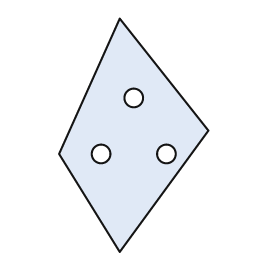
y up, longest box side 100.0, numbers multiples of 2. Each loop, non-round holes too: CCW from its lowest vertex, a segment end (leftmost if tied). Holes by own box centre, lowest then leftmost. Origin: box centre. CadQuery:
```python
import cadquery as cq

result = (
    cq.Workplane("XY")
    .moveTo(-6.0, -50.0)
    .lineTo(32.0, 2.0)
    .lineTo(-6.0, 50.0)
    .lineTo(-32.0, -8.0)
    .close()
    .moveTo(-14.0, -8.0)
    .circle(4.0)
    .moveTo(14.0, -8.0)
    .circle(4.0)
    .moveTo(0.0, 16.0)
    .circle(4.0)
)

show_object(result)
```